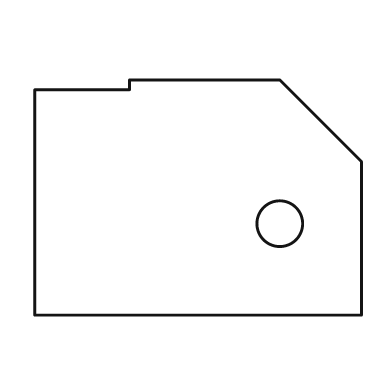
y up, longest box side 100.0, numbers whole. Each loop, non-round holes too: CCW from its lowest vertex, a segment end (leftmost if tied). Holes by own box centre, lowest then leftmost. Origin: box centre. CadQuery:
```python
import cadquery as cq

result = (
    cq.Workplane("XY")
    .moveTo(-50.0, -36.0)
    .lineTo(50.0, -36.0)
    .lineTo(50.0, 11.0)
    .lineTo(25.0, 36.0)
    .lineTo(-21.0, 36.0)
    .lineTo(-21.0, 33.0)
    .lineTo(-50.0, 33.0)
    .close()
    .moveTo(25.0, -8.0)
    .circle(7.0)
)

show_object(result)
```